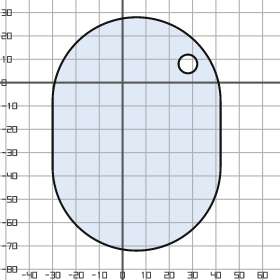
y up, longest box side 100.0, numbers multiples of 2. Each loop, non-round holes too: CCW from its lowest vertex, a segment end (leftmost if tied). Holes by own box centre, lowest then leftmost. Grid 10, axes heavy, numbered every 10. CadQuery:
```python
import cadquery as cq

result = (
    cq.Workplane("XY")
    .moveTo(-30.0, -36.0)
    .threePointArc((6.0, -72.0), (42.0, -36.0))
    .lineTo(42.0, -8.0)
    .threePointArc((6.0, 28.0), (-30.0, -8.0))
    .close()
    .moveTo(28.0, 8.0)
    .circle(4.0)
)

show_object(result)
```